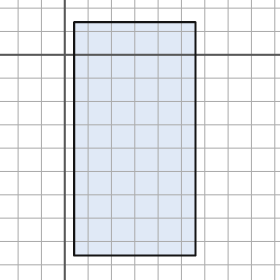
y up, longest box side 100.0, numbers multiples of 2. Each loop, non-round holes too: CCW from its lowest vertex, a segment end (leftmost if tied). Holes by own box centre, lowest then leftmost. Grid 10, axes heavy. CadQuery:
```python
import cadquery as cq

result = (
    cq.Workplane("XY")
    .moveTo(4.0, -86.0)
    .lineTo(56.0, -86.0)
    .lineTo(56.0, 14.0)
    .lineTo(4.0, 14.0)
    .close()
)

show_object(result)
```